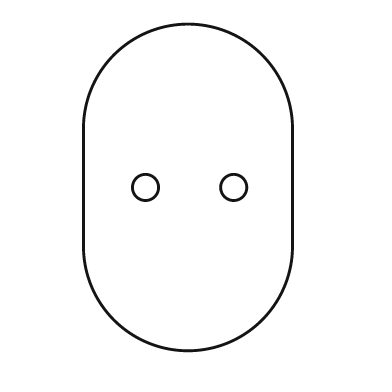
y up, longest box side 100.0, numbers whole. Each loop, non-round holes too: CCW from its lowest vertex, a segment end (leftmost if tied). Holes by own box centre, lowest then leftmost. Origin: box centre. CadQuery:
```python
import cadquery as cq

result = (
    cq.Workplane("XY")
    .moveTo(-32.0, -18.0)
    .threePointArc((0.0, -50.0), (32.0, -18.0))
    .lineTo(32.0, 18.0)
    .threePointArc((0.0, 50.0), (-32.0, 18.0))
    .close()
    .moveTo(-13.0, 0.0)
    .circle(4.0)
    .moveTo(14.0, 0.0)
    .circle(4.0)
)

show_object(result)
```